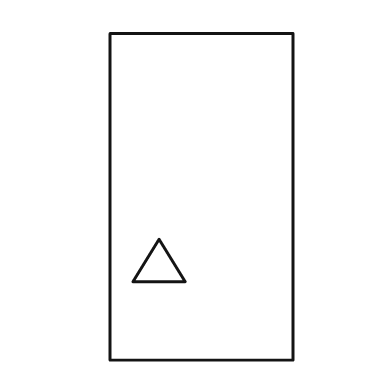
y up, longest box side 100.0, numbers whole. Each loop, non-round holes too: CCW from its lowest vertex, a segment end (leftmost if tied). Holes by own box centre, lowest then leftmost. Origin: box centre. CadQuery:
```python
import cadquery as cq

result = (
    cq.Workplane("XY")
    .moveTo(-28.0, -50.0)
    .lineTo(28.0, -50.0)
    .lineTo(28.0, 50.0)
    .lineTo(-28.0, 50.0)
    .close()
    .moveTo(-21.0, -26.0)
    .lineTo(-5.0, -26.0)
    .lineTo(-13.0, -13.0)
    .close()
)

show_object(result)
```